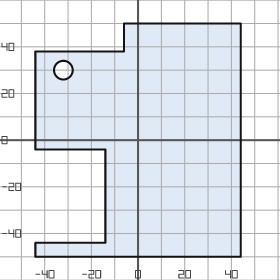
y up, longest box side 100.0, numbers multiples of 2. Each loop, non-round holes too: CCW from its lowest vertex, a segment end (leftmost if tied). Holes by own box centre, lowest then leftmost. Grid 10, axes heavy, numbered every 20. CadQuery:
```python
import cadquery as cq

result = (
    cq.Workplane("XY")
    .moveTo(-44.0, -50.0)
    .lineTo(44.0, -50.0)
    .lineTo(44.0, 50.0)
    .lineTo(-6.0, 50.0)
    .lineTo(-6.0, 38.0)
    .lineTo(-44.0, 38.0)
    .lineTo(-44.0, -4.0)
    .lineTo(-14.0, -4.0)
    .lineTo(-14.0, -44.0)
    .lineTo(-44.0, -44.0)
    .close()
    .moveTo(-32.0, 30.0)
    .circle(4.0)
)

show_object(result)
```